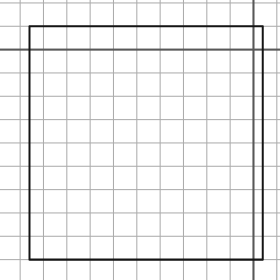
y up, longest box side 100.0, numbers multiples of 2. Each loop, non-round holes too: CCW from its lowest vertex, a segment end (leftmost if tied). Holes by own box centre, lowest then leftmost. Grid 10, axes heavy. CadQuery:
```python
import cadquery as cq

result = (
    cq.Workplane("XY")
    .moveTo(-96.0, -90.0)
    .lineTo(4.0, -90.0)
    .lineTo(4.0, 10.0)
    .lineTo(-96.0, 10.0)
    .close()
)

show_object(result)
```